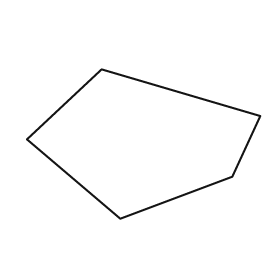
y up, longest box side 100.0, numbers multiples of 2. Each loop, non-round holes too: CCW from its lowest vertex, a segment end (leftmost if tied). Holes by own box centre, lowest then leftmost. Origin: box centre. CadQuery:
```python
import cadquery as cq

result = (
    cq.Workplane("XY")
    .moveTo(-10.0, -32.0)
    .lineTo(38.0, -14.0)
    .lineTo(50.0, 12.0)
    .lineTo(-18.0, 32.0)
    .lineTo(-50.0, 2.0)
    .close()
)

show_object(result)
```